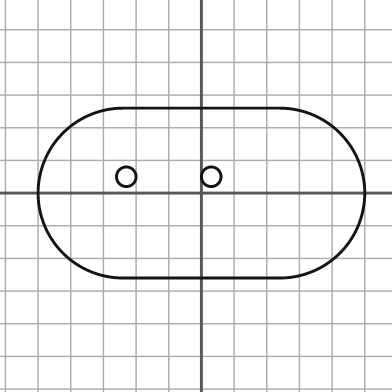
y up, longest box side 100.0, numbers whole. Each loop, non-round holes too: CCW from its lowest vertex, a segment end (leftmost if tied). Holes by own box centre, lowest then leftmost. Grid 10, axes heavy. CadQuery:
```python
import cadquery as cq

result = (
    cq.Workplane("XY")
    .moveTo(-24.0, -26.0)
    .lineTo(24.0, -26.0)
    .threePointArc((50.0, 0.0), (24.0, 26.0))
    .lineTo(-24.0, 26.0)
    .threePointArc((-50.0, 0.0), (-24.0, -26.0))
    .close()
    .moveTo(-23.0, 5.0)
    .circle(3.0)
    .moveTo(3.0, 5.0)
    .circle(3.0)
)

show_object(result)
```